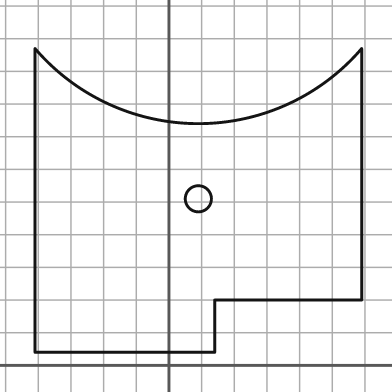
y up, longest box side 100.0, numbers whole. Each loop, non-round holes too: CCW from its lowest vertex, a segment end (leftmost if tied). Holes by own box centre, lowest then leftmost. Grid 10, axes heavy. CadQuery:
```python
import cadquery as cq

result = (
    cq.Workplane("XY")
    .moveTo(-41.0, 4.0)
    .lineTo(14.0, 4.0)
    .lineTo(14.0, 20.0)
    .lineTo(59.0, 20.0)
    .lineTo(59.0, 97.0)
    .threePointArc((9.0, 74.0), (-41.0, 97.0))
    .close()
    .moveTo(9.0, 51.0)
    .circle(4.0)
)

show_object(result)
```